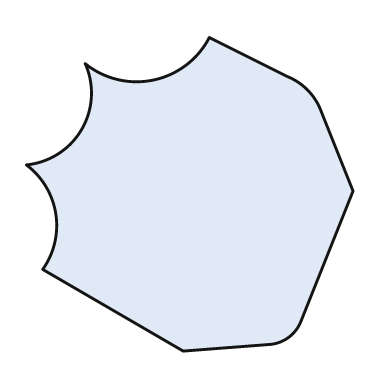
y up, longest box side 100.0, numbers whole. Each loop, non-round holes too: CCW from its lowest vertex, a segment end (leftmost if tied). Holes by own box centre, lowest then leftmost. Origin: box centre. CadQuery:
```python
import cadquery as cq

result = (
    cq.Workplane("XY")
    .moveTo(-2.0, -48.0)
    .lineTo(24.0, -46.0)
    .threePointArc((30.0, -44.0), (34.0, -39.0))
    .lineTo(50.0, 1.0)
    .lineTo(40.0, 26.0)
    .threePointArc((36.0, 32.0), (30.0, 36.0))
    .lineTo(6.0, 48.0)
    .threePointArc((-11.0, 35.0), (-32.0, 40.0))
    .threePointArc((-33.0, 20.0), (-50.0, 9.0))
    .threePointArc((-41.0, -6.0), (-45.0, -23.0))
    .close()
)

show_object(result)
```